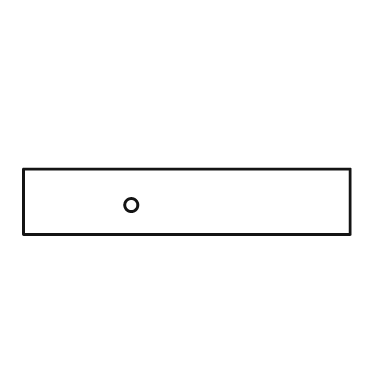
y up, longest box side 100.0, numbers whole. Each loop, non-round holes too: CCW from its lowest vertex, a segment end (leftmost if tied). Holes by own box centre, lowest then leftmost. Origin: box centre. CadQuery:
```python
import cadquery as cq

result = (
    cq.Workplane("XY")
    .moveTo(-50.0, -10.0)
    .lineTo(50.0, -10.0)
    .lineTo(50.0, 10.0)
    .lineTo(-50.0, 10.0)
    .close()
    .moveTo(-17.0, -1.0)
    .circle(2.0)
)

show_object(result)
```